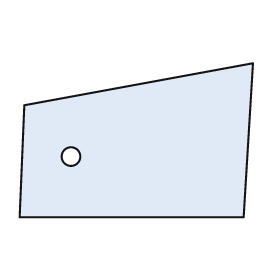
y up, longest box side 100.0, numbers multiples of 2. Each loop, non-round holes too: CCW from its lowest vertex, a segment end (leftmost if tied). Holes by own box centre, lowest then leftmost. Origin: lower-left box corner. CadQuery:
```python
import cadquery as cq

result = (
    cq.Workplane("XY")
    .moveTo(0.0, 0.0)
    .lineTo(96.0, 0.0)
    .lineTo(100.0, 66.0)
    .lineTo(2.0, 48.0)
    .close()
    .moveTo(22.0, 26.0)
    .circle(4.0)
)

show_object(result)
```